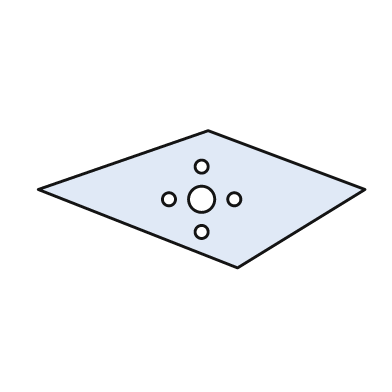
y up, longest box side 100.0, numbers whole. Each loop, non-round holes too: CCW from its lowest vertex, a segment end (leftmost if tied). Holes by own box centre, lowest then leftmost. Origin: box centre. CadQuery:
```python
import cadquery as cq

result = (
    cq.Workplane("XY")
    .moveTo(11.0, -21.0)
    .lineTo(50.0, 3.0)
    .lineTo(2.0, 21.0)
    .lineTo(-50.0, 3.0)
    .close()
    .moveTo(0.0, -10.0)
    .circle(2.0)
    .moveTo(-10.0, 0.0)
    .circle(2.0)
    .moveTo(0.0, 0.0)
    .circle(4.0)
    .moveTo(10.0, 0.0)
    .circle(2.0)
    .moveTo(0.0, 10.0)
    .circle(2.0)
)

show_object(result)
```